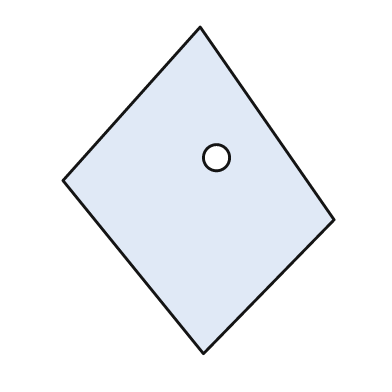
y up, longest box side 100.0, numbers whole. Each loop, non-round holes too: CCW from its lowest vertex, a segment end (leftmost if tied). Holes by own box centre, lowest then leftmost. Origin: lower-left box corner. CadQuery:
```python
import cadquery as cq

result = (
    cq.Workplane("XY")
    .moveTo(43.0, 0.0)
    .lineTo(83.0, 41.0)
    .lineTo(42.0, 100.0)
    .lineTo(0.0, 53.0)
    .close()
    .moveTo(47.0, 60.0)
    .circle(4.0)
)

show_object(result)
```